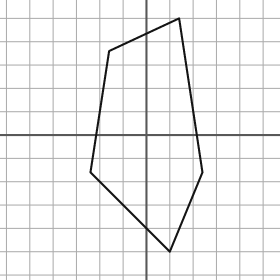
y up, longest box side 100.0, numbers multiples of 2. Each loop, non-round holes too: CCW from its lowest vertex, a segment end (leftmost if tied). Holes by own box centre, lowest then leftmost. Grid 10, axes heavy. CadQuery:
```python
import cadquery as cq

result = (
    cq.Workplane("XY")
    .moveTo(10.0, -50.0)
    .lineTo(24.0, -16.0)
    .lineTo(14.0, 50.0)
    .lineTo(-16.0, 36.0)
    .lineTo(-24.0, -16.0)
    .close()
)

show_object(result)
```